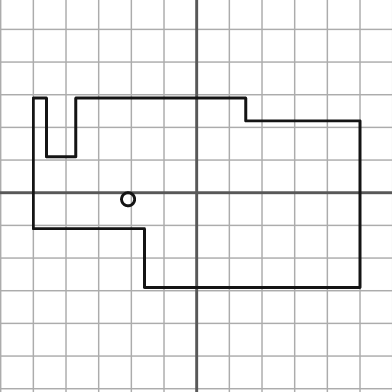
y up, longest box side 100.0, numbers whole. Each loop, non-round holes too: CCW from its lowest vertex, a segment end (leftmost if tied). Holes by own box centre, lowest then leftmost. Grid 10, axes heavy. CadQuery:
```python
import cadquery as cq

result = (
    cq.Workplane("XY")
    .moveTo(-16.0, -29.0)
    .lineTo(50.0, -29.0)
    .lineTo(50.0, 22.0)
    .lineTo(15.0, 22.0)
    .lineTo(15.0, 29.0)
    .lineTo(-37.0, 29.0)
    .lineTo(-37.0, 11.0)
    .lineTo(-46.0, 11.0)
    .lineTo(-46.0, 29.0)
    .lineTo(-50.0, 29.0)
    .lineTo(-50.0, -11.0)
    .lineTo(-16.0, -11.0)
    .close()
    .moveTo(-21.0, -2.0)
    .circle(2.0)
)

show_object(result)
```